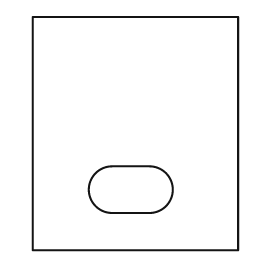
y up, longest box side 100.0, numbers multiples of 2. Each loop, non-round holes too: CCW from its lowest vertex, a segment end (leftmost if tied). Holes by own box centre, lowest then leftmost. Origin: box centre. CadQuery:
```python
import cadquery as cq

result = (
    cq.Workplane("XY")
    .moveTo(-44.0, -50.0)
    .lineTo(44.0, -50.0)
    .lineTo(44.0, 50.0)
    .lineTo(-44.0, 50.0)
    .close()
    .moveTo(-10.0, -34.0)
    .lineTo(6.0, -34.0)
    .threePointArc((16.0, -24.0), (6.0, -14.0))
    .lineTo(-10.0, -14.0)
    .threePointArc((-20.0, -24.0), (-10.0, -34.0))
    .close()
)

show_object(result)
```